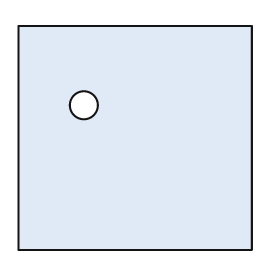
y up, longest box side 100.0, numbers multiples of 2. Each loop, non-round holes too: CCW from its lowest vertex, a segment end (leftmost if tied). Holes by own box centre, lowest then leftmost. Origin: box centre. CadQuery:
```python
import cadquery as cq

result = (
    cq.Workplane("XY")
    .moveTo(-50.0, -48.0)
    .lineTo(50.0, -48.0)
    .lineTo(50.0, 48.0)
    .lineTo(-50.0, 48.0)
    .close()
    .moveTo(-22.0, 14.0)
    .circle(6.0)
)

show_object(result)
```